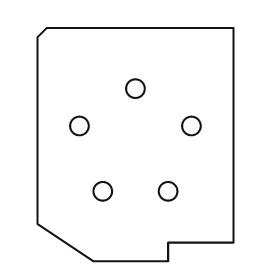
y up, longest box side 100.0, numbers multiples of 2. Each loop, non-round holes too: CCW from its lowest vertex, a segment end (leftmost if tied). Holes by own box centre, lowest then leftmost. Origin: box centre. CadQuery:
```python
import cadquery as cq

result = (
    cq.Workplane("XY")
    .moveTo(-18.0, -50.0)
    .lineTo(14.0, -50.0)
    .lineTo(14.0, -42.0)
    .lineTo(42.0, -42.0)
    .lineTo(42.0, 50.0)
    .lineTo(-38.0, 50.0)
    .lineTo(-42.0, 46.0)
    .lineTo(-42.0, -34.0)
    .close()
    .moveTo(-14.0, -20.0)
    .circle(4.0)
    .moveTo(14.0, -20.0)
    .circle(4.0)
    .moveTo(-24.0, 8.0)
    .circle(4.0)
    .moveTo(24.0, 8.0)
    .circle(4.0)
    .moveTo(0.0, 24.0)
    .circle(4.0)
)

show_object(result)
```